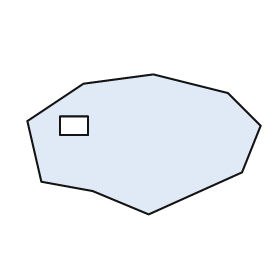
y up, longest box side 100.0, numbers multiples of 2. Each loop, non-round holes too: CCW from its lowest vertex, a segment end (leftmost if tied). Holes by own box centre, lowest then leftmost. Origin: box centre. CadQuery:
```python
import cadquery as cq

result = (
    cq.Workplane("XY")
    .moveTo(2.0, -30.0)
    .lineTo(42.0, -12.0)
    .lineTo(50.0, 8.0)
    .lineTo(36.0, 22.0)
    .lineTo(4.0, 30.0)
    .lineTo(-26.0, 26.0)
    .lineTo(-50.0, 10.0)
    .lineTo(-44.0, -16.0)
    .lineTo(-22.0, -20.0)
    .close()
    .moveTo(-36.0, 4.0)
    .lineTo(-24.0, 4.0)
    .lineTo(-24.0, 12.0)
    .lineTo(-36.0, 12.0)
    .close()
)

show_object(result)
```